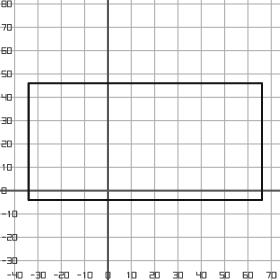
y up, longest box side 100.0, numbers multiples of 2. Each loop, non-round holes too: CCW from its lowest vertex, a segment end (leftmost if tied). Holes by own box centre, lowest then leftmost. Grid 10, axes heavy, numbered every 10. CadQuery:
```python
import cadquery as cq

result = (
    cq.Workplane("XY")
    .moveTo(-34.0, -4.0)
    .lineTo(66.0, -4.0)
    .lineTo(66.0, 46.0)
    .lineTo(-34.0, 46.0)
    .close()
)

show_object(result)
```